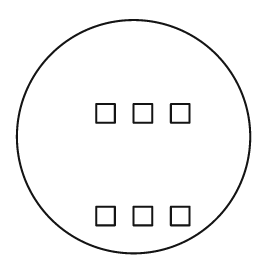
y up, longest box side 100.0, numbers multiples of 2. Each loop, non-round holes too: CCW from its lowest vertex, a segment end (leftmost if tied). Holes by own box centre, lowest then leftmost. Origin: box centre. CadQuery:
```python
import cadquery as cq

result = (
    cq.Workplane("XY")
    .moveTo(0.0, 0.0)
    .circle(50.0)
    .moveTo(-16.0, -38.0)
    .lineTo(-8.0, -38.0)
    .lineTo(-8.0, -30.0)
    .lineTo(-16.0, -30.0)
    .close()
    .moveTo(0.0, -38.0)
    .lineTo(8.0, -38.0)
    .lineTo(8.0, -30.0)
    .lineTo(0.0, -30.0)
    .close()
    .moveTo(16.0, -38.0)
    .lineTo(24.0, -38.0)
    .lineTo(24.0, -30.0)
    .lineTo(16.0, -30.0)
    .close()
    .moveTo(-16.0, 6.0)
    .lineTo(-8.0, 6.0)
    .lineTo(-8.0, 14.0)
    .lineTo(-16.0, 14.0)
    .close()
    .moveTo(0.0, 6.0)
    .lineTo(8.0, 6.0)
    .lineTo(8.0, 14.0)
    .lineTo(0.0, 14.0)
    .close()
    .moveTo(16.0, 6.0)
    .lineTo(24.0, 6.0)
    .lineTo(24.0, 14.0)
    .lineTo(16.0, 14.0)
    .close()
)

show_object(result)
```